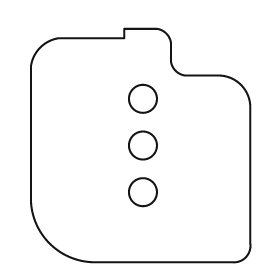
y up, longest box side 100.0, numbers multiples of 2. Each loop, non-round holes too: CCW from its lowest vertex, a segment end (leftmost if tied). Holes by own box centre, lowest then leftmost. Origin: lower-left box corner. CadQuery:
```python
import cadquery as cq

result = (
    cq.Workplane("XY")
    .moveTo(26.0, 0.0)
    .lineTo(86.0, 0.0)
    .threePointArc((92.0, 2.0), (94.0, 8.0))
    .lineTo(94.0, 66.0)
    .threePointArc((90.0, 76.0), (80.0, 80.0))
    .lineTo(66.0, 80.0)
    .threePointArc((62.0, 82.0), (60.0, 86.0))
    .lineTo(60.0, 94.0)
    .threePointArc((58.0, 98.0), (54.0, 100.0))
    .lineTo(40.0, 100.0)
    .lineTo(40.0, 96.0)
    .lineTo(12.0, 96.0)
    .threePointArc((4.0, 92.0), (0.0, 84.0))
    .lineTo(0.0, 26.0)
    .threePointArc((8.0, 8.0), (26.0, 0.0))
    .close()
    .moveTo(48.0, 30.0)
    .circle(6.0)
    .moveTo(48.0, 50.0)
    .circle(6.0)
    .moveTo(48.0, 70.0)
    .circle(6.0)
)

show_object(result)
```